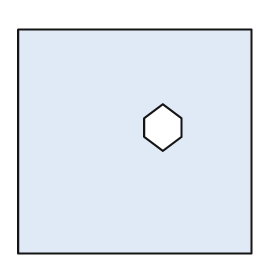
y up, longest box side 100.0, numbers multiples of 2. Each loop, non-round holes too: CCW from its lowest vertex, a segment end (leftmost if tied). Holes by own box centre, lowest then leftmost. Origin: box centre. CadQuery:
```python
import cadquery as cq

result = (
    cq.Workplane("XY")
    .moveTo(-50.0, -48.0)
    .lineTo(50.0, -48.0)
    .lineTo(50.0, 48.0)
    .lineTo(-50.0, 48.0)
    .close()
    .moveTo(12.0, -4.0)
    .lineTo(20.0, 2.0)
    .lineTo(20.0, 10.0)
    .lineTo(12.0, 16.0)
    .lineTo(4.0, 10.0)
    .lineTo(4.0, 2.0)
    .close()
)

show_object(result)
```